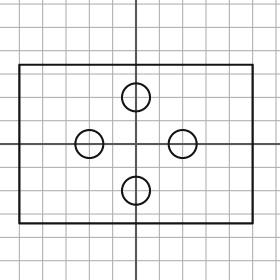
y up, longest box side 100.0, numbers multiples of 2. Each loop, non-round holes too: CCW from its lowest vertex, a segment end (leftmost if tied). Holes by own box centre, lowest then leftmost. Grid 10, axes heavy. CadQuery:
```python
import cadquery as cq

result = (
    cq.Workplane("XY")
    .moveTo(-50.0, -34.0)
    .lineTo(50.0, -34.0)
    .lineTo(50.0, 34.0)
    .lineTo(-50.0, 34.0)
    .close()
    .moveTo(0.0, -20.0)
    .circle(6.0)
    .moveTo(-20.0, 0.0)
    .circle(6.0)
    .moveTo(20.0, 0.0)
    .circle(6.0)
    .moveTo(0.0, 20.0)
    .circle(6.0)
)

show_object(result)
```